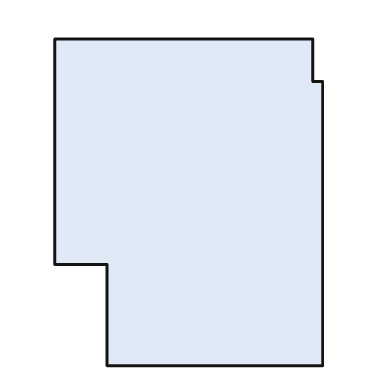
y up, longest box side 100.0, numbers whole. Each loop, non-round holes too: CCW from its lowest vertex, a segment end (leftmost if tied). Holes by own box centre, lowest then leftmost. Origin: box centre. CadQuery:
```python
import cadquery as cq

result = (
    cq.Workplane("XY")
    .moveTo(-25.0, -50.0)
    .lineTo(41.0, -50.0)
    .lineTo(41.0, 37.0)
    .lineTo(38.0, 37.0)
    .lineTo(38.0, 50.0)
    .lineTo(-41.0, 50.0)
    .lineTo(-41.0, -19.0)
    .lineTo(-25.0, -19.0)
    .close()
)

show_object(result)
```